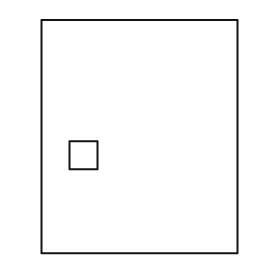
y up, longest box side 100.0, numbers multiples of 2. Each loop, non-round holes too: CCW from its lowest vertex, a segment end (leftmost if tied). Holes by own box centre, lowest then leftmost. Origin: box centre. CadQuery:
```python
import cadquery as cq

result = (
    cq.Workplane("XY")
    .moveTo(-42.0, -50.0)
    .lineTo(42.0, -50.0)
    .lineTo(42.0, 50.0)
    .lineTo(-42.0, 50.0)
    .close()
    .moveTo(-30.0, -14.0)
    .lineTo(-18.0, -14.0)
    .lineTo(-18.0, -2.0)
    .lineTo(-30.0, -2.0)
    .close()
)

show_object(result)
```